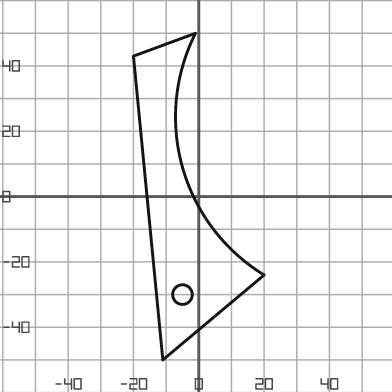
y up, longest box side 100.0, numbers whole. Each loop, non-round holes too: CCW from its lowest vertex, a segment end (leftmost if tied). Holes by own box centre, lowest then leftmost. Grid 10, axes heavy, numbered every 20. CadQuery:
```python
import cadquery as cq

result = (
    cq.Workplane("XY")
    .moveTo(-11.0, -50.0)
    .lineTo(20.0, -24.0)
    .threePointArc((-5.0, 9.0), (-1.0, 50.0))
    .lineTo(-20.0, 43.0)
    .close()
    .moveTo(-5.0, -30.0)
    .circle(3.0)
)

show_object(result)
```